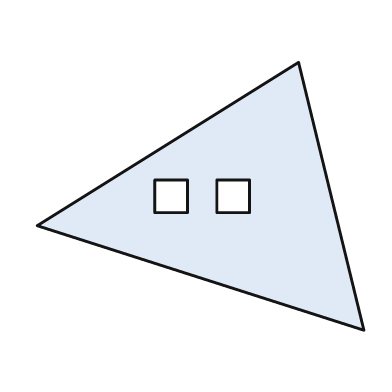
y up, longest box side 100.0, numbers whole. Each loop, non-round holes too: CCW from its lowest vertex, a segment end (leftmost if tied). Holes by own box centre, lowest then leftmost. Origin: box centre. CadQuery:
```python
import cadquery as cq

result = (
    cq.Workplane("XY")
    .moveTo(50.0, -41.0)
    .lineTo(30.0, 41.0)
    .lineTo(-50.0, -9.0)
    .close()
    .moveTo(-14.0, -5.0)
    .lineTo(-4.0, -5.0)
    .lineTo(-4.0, 5.0)
    .lineTo(-14.0, 5.0)
    .close()
    .moveTo(5.0, -5.0)
    .lineTo(15.0, -5.0)
    .lineTo(15.0, 5.0)
    .lineTo(5.0, 5.0)
    .close()
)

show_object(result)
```